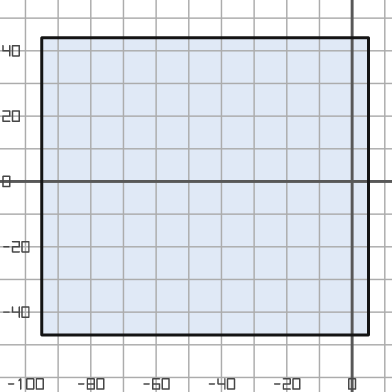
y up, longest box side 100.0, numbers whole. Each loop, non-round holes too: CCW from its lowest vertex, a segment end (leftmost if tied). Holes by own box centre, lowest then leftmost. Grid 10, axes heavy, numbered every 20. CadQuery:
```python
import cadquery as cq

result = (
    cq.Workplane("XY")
    .moveTo(-95.0, -47.0)
    .lineTo(5.0, -47.0)
    .lineTo(5.0, 44.0)
    .lineTo(-95.0, 44.0)
    .close()
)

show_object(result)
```